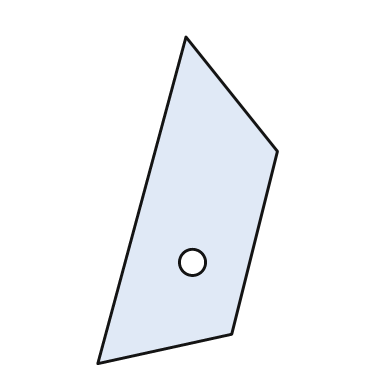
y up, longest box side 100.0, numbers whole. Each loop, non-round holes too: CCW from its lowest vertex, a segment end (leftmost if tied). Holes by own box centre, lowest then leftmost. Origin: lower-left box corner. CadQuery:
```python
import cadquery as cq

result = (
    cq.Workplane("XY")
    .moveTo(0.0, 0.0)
    .lineTo(41.0, 9.0)
    .lineTo(55.0, 65.0)
    .lineTo(27.0, 100.0)
    .close()
    .moveTo(29.0, 31.0)
    .circle(4.0)
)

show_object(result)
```